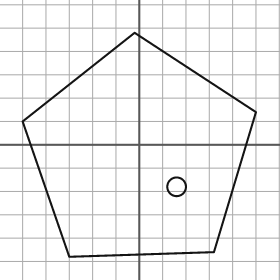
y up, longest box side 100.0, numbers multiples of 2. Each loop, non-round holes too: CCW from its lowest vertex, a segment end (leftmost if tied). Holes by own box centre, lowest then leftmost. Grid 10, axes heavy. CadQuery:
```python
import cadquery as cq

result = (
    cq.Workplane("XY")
    .moveTo(-30.0, -48.0)
    .lineTo(32.0, -46.0)
    .lineTo(50.0, 14.0)
    .lineTo(-2.0, 48.0)
    .lineTo(-50.0, 10.0)
    .close()
    .moveTo(16.0, -18.0)
    .circle(4.0)
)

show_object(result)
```